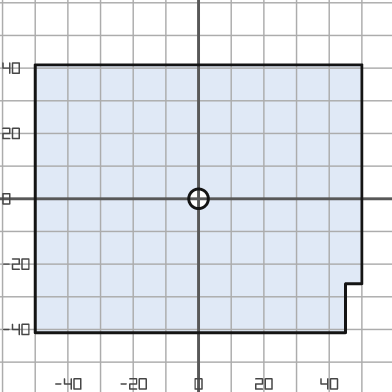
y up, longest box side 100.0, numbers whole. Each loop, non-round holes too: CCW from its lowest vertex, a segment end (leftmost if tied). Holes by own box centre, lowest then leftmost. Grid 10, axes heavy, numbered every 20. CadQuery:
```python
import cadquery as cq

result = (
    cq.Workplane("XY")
    .moveTo(-50.0, -41.0)
    .lineTo(45.0, -41.0)
    .lineTo(45.0, -26.0)
    .lineTo(50.0, -26.0)
    .lineTo(50.0, 41.0)
    .lineTo(-50.0, 41.0)
    .close()
    .moveTo(0.0, 0.0)
    .circle(3.0)
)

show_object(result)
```